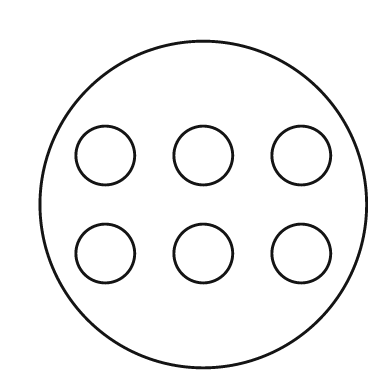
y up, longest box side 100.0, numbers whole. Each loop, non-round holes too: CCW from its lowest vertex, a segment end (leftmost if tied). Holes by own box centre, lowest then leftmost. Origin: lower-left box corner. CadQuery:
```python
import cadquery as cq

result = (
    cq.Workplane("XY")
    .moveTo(50.0, 50.0)
    .circle(50.0)
    .moveTo(20.0, 35.0)
    .circle(9.0)
    .moveTo(50.0, 35.0)
    .circle(9.0)
    .moveTo(80.0, 35.0)
    .circle(9.0)
    .moveTo(20.0, 65.0)
    .circle(9.0)
    .moveTo(50.0, 65.0)
    .circle(9.0)
    .moveTo(80.0, 65.0)
    .circle(9.0)
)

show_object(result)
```